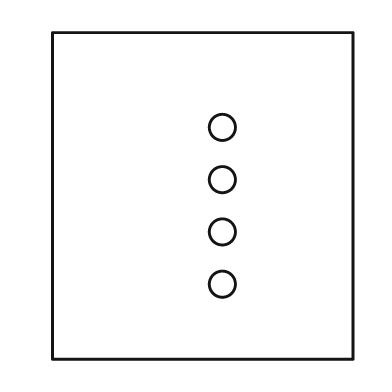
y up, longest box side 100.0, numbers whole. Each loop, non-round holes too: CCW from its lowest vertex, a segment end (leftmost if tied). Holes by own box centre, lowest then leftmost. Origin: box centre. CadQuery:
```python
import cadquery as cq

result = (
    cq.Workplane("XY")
    .moveTo(-46.0, -50.0)
    .lineTo(46.0, -50.0)
    .lineTo(46.0, 50.0)
    .lineTo(-46.0, 50.0)
    .close()
    .moveTo(6.0, -27.0)
    .circle(4.0)
    .moveTo(6.0, -11.0)
    .circle(4.0)
    .moveTo(6.0, 5.0)
    .circle(4.0)
    .moveTo(6.0, 21.0)
    .circle(4.0)
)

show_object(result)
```